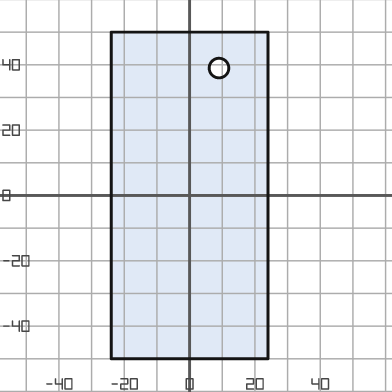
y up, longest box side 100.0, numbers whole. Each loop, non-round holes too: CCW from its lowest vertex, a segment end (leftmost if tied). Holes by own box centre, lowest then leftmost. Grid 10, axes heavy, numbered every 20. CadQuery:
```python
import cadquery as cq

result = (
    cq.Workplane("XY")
    .moveTo(-24.0, -50.0)
    .lineTo(24.0, -50.0)
    .lineTo(24.0, 50.0)
    .lineTo(-24.0, 50.0)
    .close()
    .moveTo(9.0, 39.0)
    .circle(3.0)
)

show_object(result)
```